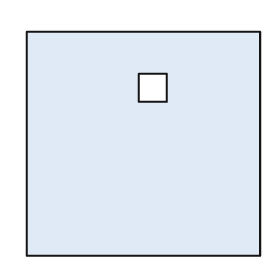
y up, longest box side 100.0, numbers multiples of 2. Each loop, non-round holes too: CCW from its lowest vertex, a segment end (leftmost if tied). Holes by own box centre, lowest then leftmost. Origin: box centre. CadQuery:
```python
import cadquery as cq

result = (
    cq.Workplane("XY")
    .moveTo(-50.0, -48.0)
    .lineTo(50.0, -48.0)
    .lineTo(50.0, 48.0)
    .lineTo(-50.0, 48.0)
    .close()
    .moveTo(-2.0, 18.0)
    .lineTo(10.0, 18.0)
    .lineTo(10.0, 30.0)
    .lineTo(-2.0, 30.0)
    .close()
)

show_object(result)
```